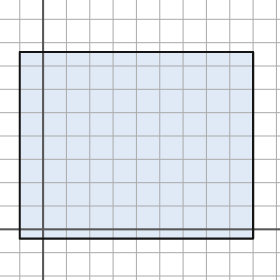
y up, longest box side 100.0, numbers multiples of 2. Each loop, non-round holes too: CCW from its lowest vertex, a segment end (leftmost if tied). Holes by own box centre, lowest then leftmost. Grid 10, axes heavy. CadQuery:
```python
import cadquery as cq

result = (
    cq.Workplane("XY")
    .moveTo(-10.0, -4.0)
    .lineTo(90.0, -4.0)
    .lineTo(90.0, 76.0)
    .lineTo(-10.0, 76.0)
    .close()
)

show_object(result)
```